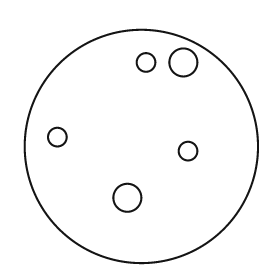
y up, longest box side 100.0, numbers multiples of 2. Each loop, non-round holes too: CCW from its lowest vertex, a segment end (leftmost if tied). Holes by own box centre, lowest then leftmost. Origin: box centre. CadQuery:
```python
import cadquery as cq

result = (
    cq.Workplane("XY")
    .moveTo(0.0, 0.0)
    .circle(50.0)
    .moveTo(-6.0, -22.0)
    .circle(6.0)
    .moveTo(20.0, -2.0)
    .circle(4.0)
    .moveTo(-36.0, 4.0)
    .circle(4.0)
    .moveTo(2.0, 36.0)
    .circle(4.0)
    .moveTo(18.0, 36.0)
    .circle(6.0)
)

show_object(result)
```